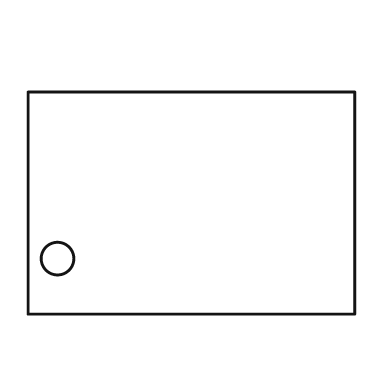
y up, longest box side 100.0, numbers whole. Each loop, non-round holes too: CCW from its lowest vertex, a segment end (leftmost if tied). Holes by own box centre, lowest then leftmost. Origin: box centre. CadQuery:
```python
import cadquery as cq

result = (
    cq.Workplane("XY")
    .moveTo(-50.0, -34.0)
    .lineTo(50.0, -34.0)
    .lineTo(50.0, 34.0)
    .lineTo(-50.0, 34.0)
    .close()
    .moveTo(-41.0, -17.0)
    .circle(5.0)
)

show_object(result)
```